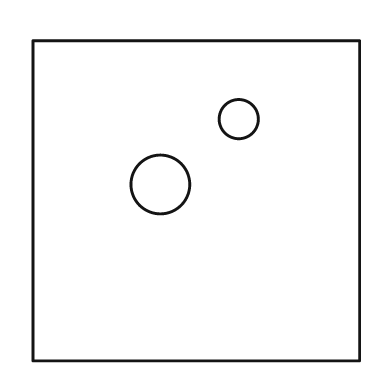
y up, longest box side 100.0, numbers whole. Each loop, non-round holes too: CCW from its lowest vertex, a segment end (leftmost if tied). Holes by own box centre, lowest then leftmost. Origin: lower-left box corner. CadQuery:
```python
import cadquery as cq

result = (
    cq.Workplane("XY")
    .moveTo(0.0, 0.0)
    .lineTo(100.0, 0.0)
    .lineTo(100.0, 98.0)
    .lineTo(0.0, 98.0)
    .close()
    .moveTo(39.0, 54.0)
    .circle(9.0)
    .moveTo(63.0, 74.0)
    .circle(6.0)
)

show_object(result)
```